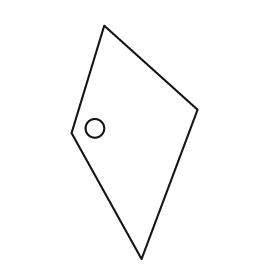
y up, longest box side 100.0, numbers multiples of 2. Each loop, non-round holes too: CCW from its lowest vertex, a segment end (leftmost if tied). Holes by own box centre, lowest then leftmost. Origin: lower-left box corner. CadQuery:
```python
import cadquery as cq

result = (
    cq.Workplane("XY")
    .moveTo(30.0, 0.0)
    .lineTo(54.0, 64.0)
    .lineTo(14.0, 100.0)
    .lineTo(0.0, 54.0)
    .close()
    .moveTo(10.0, 56.0)
    .circle(4.0)
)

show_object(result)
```